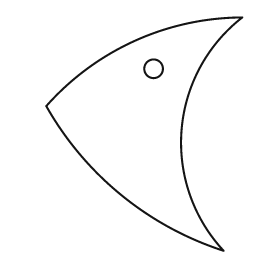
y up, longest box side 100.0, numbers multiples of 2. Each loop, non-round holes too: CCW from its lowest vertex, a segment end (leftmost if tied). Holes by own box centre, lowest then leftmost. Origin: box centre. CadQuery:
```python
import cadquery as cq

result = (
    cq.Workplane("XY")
    .moveTo(34.0, -50.0)
    .threePointArc((16.0, 2.0), (42.0, 50.0))
    .threePointArc((-4.0, 40.0), (-42.0, 12.0))
    .threePointArc((-10.0, -26.0), (34.0, -50.0))
    .close()
    .moveTo(4.0, 28.0)
    .circle(4.0)
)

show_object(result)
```